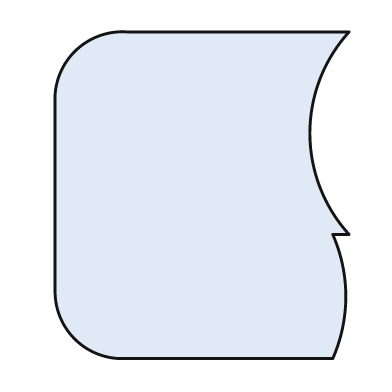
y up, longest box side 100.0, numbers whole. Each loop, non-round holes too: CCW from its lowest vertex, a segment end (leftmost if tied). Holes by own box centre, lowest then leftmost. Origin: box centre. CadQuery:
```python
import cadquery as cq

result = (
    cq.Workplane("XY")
    .moveTo(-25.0, -50.0)
    .lineTo(40.0, -50.0)
    .threePointArc((44.0, -31.0), (40.0, -12.0))
    .lineTo(45.0, -12.0)
    .threePointArc((33.0, 19.0), (45.0, 50.0))
    .lineTo(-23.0, 50.0)
    .threePointArc((-39.0, 44.0), (-45.0, 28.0))
    .lineTo(-45.0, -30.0)
    .threePointArc((-39.0, -44.0), (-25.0, -50.0))
    .close()
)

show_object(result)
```